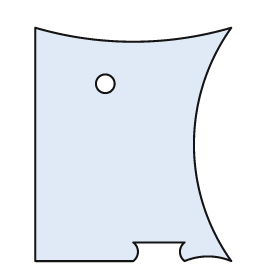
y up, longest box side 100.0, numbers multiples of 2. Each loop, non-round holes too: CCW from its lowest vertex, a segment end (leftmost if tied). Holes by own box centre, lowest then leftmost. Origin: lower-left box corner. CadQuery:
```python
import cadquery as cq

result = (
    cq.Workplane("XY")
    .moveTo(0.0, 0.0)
    .lineTo(42.0, 0.0)
    .threePointArc((44.0, 4.0), (42.0, 8.0))
    .lineTo(64.0, 8.0)
    .threePointArc((62.0, 4.0), (64.0, 0.0))
    .threePointArc((74.0, 2.0), (84.0, 0.0))
    .threePointArc((68.0, 50.0), (84.0, 100.0))
    .threePointArc((42.0, 94.0), (0.0, 100.0))
    .close()
    .moveTo(30.0, 76.0)
    .circle(4.0)
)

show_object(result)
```